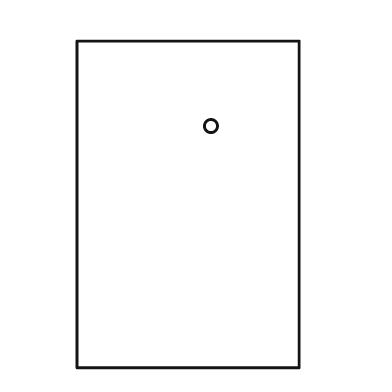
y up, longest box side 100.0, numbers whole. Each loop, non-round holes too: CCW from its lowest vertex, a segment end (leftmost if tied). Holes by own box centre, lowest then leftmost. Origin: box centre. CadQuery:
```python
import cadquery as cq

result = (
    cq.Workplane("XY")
    .moveTo(-34.0, -50.0)
    .lineTo(34.0, -50.0)
    .lineTo(34.0, 50.0)
    .lineTo(-34.0, 50.0)
    .close()
    .moveTo(7.0, 24.0)
    .circle(2.0)
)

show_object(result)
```